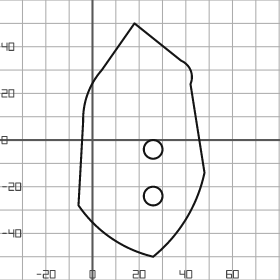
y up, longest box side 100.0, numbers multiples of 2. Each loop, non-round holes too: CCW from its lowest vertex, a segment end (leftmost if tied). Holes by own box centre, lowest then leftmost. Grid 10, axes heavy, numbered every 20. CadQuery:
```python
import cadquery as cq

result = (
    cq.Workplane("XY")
    .moveTo(26.0, -50.0)
    .threePointArc((40.0, -34.0), (48.0, -14.0))
    .lineTo(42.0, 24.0)
    .threePointArc((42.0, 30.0), (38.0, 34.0))
    .lineTo(18.0, 50.0)
    .lineTo(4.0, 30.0)
    .threePointArc((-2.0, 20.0), (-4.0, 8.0))
    .lineTo(-6.0, -28.0)
    .threePointArc((8.0, -42.0), (26.0, -50.0))
    .close()
    .moveTo(26.0, -24.0)
    .circle(4.0)
    .moveTo(26.0, -4.0)
    .circle(4.0)
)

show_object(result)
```